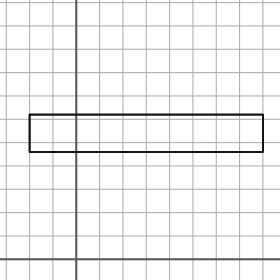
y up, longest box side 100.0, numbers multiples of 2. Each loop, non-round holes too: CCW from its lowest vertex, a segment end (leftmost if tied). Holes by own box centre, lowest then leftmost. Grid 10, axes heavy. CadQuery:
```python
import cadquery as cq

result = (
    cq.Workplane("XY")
    .moveTo(-20.0, 46.0)
    .lineTo(80.0, 46.0)
    .lineTo(80.0, 62.0)
    .lineTo(-20.0, 62.0)
    .close()
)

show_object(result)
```